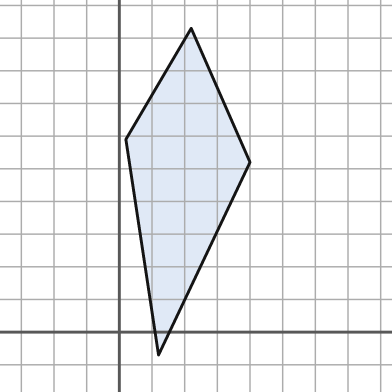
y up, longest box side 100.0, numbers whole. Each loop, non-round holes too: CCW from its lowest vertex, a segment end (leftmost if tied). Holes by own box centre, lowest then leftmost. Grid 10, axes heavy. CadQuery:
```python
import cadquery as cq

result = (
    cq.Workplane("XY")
    .moveTo(12.0, -7.0)
    .lineTo(40.0, 52.0)
    .lineTo(22.0, 93.0)
    .lineTo(2.0, 59.0)
    .close()
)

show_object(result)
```